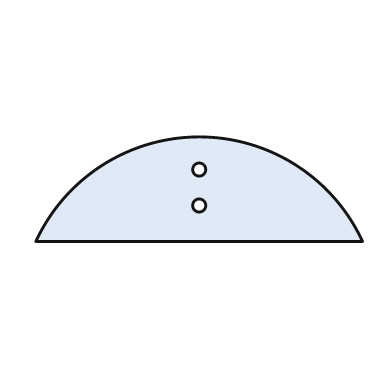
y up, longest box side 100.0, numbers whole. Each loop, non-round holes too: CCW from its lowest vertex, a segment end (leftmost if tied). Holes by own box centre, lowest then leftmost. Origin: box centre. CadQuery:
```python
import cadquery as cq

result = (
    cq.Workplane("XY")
    .moveTo(-50.0, -16.0)
    .lineTo(50.0, -16.0)
    .threePointArc((0.0, 16.0), (-50.0, -16.0))
    .close()
    .moveTo(0.0, -5.0)
    .circle(2.0)
    .moveTo(0.0, 6.0)
    .circle(2.0)
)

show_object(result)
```